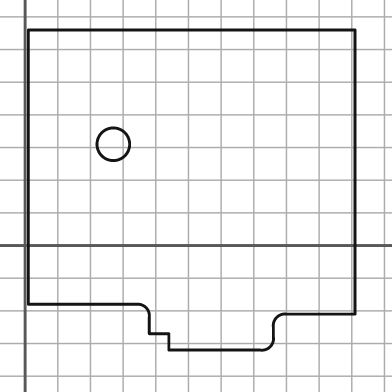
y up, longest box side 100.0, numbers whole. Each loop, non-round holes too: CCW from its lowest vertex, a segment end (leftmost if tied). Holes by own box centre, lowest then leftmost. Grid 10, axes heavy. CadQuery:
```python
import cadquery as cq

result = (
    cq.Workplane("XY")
    .moveTo(44.0, -32.0)
    .lineTo(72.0, -32.0)
    .threePointArc((75.0, -31.0), (76.0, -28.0))
    .lineTo(76.0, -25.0)
    .threePointArc((77.0, -22.0), (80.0, -21.0))
    .lineTo(101.0, -21.0)
    .lineTo(101.0, 66.0)
    .lineTo(1.0, 66.0)
    .lineTo(1.0, -18.0)
    .lineTo(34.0, -18.0)
    .threePointArc((37.0, -19.0), (38.0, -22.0))
    .lineTo(38.0, -27.0)
    .lineTo(44.0, -27.0)
    .close()
    .moveTo(27.0, 31.0)
    .circle(5.0)
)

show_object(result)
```